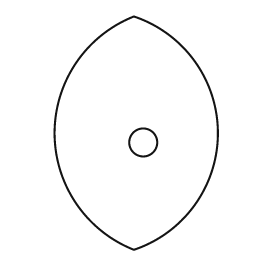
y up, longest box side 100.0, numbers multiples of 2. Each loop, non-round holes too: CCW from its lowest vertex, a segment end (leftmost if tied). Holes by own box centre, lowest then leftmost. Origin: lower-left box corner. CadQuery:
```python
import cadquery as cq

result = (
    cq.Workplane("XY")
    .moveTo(34.0, 0.0)
    .threePointArc((70.0, 50.0), (34.0, 100.0))
    .threePointArc((0.0, 50.0), (34.0, 0.0))
    .close()
    .moveTo(38.0, 46.0)
    .circle(6.0)
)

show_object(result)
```